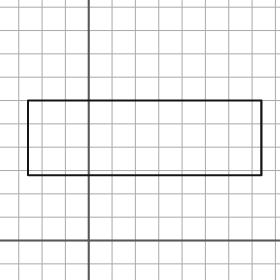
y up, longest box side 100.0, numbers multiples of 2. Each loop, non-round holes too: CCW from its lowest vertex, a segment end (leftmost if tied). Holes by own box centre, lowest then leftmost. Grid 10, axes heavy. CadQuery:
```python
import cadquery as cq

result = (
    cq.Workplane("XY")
    .moveTo(-26.0, 28.0)
    .lineTo(74.0, 28.0)
    .lineTo(74.0, 60.0)
    .lineTo(-26.0, 60.0)
    .close()
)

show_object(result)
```